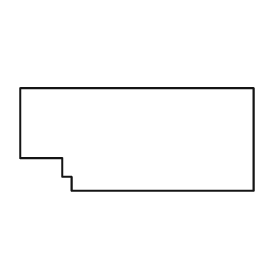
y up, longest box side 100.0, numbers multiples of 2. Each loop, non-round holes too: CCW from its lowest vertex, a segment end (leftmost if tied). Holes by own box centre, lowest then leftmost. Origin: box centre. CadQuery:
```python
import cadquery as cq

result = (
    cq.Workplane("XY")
    .moveTo(-28.0, -22.0)
    .lineTo(50.0, -22.0)
    .lineTo(50.0, 22.0)
    .lineTo(-50.0, 22.0)
    .lineTo(-50.0, -8.0)
    .lineTo(-32.0, -8.0)
    .lineTo(-32.0, -16.0)
    .lineTo(-28.0, -16.0)
    .close()
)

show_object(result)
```